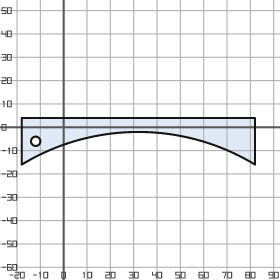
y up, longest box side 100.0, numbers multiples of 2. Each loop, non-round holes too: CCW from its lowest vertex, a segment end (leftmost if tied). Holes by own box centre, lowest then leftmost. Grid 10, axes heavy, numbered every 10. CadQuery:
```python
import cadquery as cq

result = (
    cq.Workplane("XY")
    .moveTo(-18.0, -16.0)
    .threePointArc((32.0, -2.0), (82.0, -16.0))
    .lineTo(82.0, 4.0)
    .lineTo(-18.0, 4.0)
    .close()
    .moveTo(-12.0, -6.0)
    .circle(2.0)
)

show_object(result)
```